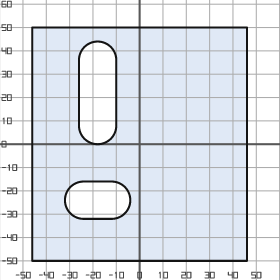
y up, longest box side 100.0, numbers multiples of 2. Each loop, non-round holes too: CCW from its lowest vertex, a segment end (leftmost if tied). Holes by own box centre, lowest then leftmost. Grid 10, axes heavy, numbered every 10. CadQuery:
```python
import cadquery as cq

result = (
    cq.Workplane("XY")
    .moveTo(-46.0, -50.0)
    .lineTo(46.0, -50.0)
    .lineTo(46.0, 50.0)
    .lineTo(-46.0, 50.0)
    .close()
    .moveTo(-24.0, -32.0)
    .lineTo(-12.0, -32.0)
    .threePointArc((-4.0, -24.0), (-12.0, -16.0))
    .lineTo(-24.0, -16.0)
    .threePointArc((-32.0, -24.0), (-24.0, -32.0))
    .close()
    .moveTo(-26.0, 8.0)
    .threePointArc((-18.0, 0.0), (-10.0, 8.0))
    .lineTo(-10.0, 36.0)
    .threePointArc((-18.0, 44.0), (-26.0, 36.0))
    .close()
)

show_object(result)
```